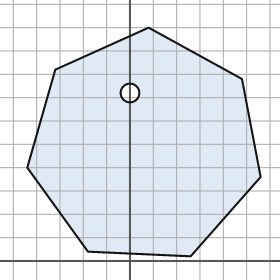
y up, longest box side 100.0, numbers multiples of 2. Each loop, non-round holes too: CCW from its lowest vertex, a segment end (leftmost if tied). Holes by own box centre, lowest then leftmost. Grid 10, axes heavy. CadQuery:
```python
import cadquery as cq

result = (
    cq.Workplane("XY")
    .moveTo(26.0, 2.0)
    .lineTo(56.0, 36.0)
    .lineTo(48.0, 78.0)
    .lineTo(8.0, 100.0)
    .lineTo(-32.0, 82.0)
    .lineTo(-44.0, 40.0)
    .lineTo(-18.0, 4.0)
    .close()
    .moveTo(0.0, 72.0)
    .circle(4.0)
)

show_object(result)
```